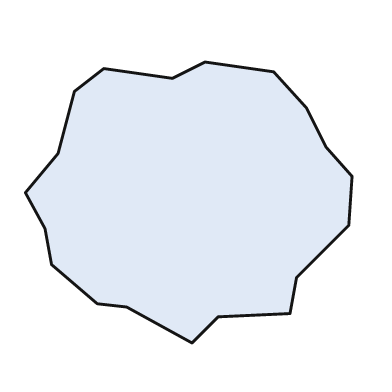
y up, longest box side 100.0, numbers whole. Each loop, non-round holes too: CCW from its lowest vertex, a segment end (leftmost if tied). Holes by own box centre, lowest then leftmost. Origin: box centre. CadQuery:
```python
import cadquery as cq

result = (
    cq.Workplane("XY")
    .moveTo(1.0, -43.0)
    .lineTo(9.0, -35.0)
    .lineTo(31.0, -34.0)
    .lineTo(33.0, -23.0)
    .lineTo(49.0, -7.0)
    .lineTo(50.0, 8.0)
    .lineTo(42.0, 17.0)
    .lineTo(36.0, 29.0)
    .lineTo(26.0, 40.0)
    .lineTo(5.0, 43.0)
    .lineTo(-5.0, 38.0)
    .lineTo(-26.0, 41.0)
    .lineTo(-35.0, 34.0)
    .lineTo(-40.0, 15.0)
    .lineTo(-50.0, 3.0)
    .lineTo(-44.0, -8.0)
    .lineTo(-42.0, -19.0)
    .lineTo(-28.0, -31.0)
    .lineTo(-19.0, -32.0)
    .close()
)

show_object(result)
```